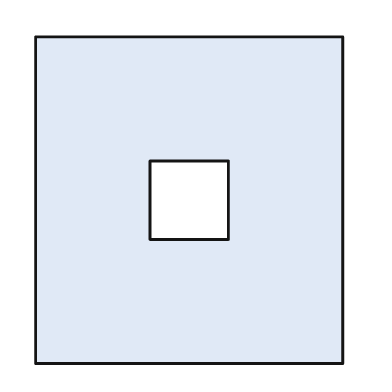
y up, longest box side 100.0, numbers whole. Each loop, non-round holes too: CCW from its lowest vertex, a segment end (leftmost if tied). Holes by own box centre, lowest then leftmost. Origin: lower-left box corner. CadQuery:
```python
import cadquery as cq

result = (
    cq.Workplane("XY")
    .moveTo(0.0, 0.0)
    .lineTo(94.0, 0.0)
    .lineTo(94.0, 100.0)
    .lineTo(0.0, 100.0)
    .close()
    .moveTo(35.0, 38.0)
    .lineTo(59.0, 38.0)
    .lineTo(59.0, 62.0)
    .lineTo(35.0, 62.0)
    .close()
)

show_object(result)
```